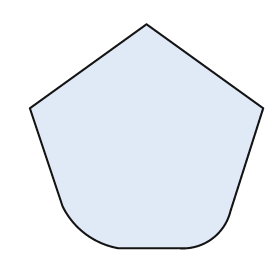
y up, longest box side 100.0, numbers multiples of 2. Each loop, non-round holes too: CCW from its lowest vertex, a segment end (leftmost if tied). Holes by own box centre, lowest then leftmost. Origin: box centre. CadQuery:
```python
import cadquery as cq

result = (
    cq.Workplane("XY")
    .moveTo(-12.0, -48.0)
    .lineTo(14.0, -48.0)
    .threePointArc((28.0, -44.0), (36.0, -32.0))
    .lineTo(50.0, 12.0)
    .lineTo(0.0, 48.0)
    .lineTo(-50.0, 12.0)
    .lineTo(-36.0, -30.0)
    .threePointArc((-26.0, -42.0), (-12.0, -48.0))
    .close()
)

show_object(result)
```